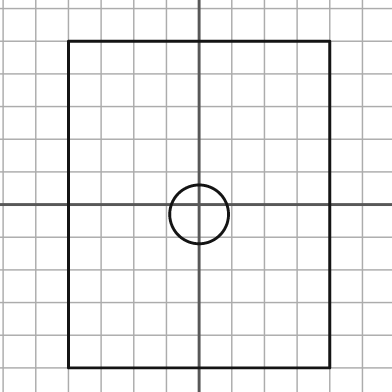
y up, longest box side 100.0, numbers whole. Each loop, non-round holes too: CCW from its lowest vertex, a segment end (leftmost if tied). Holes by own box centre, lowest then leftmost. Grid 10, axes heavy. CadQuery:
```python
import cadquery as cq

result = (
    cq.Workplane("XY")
    .moveTo(-40.0, -50.0)
    .lineTo(40.0, -50.0)
    .lineTo(40.0, 50.0)
    .lineTo(-40.0, 50.0)
    .close()
    .moveTo(0.0, -3.0)
    .circle(9.0)
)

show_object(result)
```